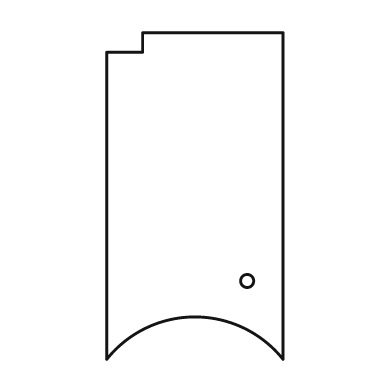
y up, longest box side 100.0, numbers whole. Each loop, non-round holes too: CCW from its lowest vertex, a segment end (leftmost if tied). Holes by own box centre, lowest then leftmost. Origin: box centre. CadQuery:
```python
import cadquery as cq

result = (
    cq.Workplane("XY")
    .moveTo(-27.0, -50.0)
    .threePointArc((0.0, -37.0), (27.0, -50.0))
    .lineTo(27.0, 50.0)
    .lineTo(-16.0, 50.0)
    .lineTo(-16.0, 44.0)
    .lineTo(-27.0, 44.0)
    .close()
    .moveTo(16.0, -26.0)
    .circle(2.0)
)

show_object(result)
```